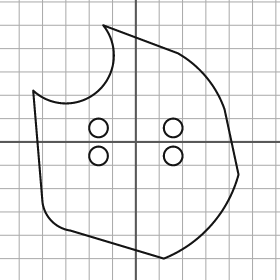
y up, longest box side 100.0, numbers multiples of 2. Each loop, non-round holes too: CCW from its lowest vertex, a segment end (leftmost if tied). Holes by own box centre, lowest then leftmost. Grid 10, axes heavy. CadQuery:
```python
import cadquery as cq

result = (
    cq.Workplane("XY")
    .moveTo(12.0, -50.0)
    .threePointArc((32.0, -36.0), (44.0, -14.0))
    .lineTo(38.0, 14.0)
    .threePointArc((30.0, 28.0), (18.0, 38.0))
    .lineTo(-14.0, 50.0)
    .threePointArc((-16.0, 22.0), (-44.0, 22.0))
    .lineTo(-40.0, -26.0)
    .threePointArc((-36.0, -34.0), (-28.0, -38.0))
    .close()
    .moveTo(-16.0, -6.0)
    .circle(4.0)
    .moveTo(16.0, -6.0)
    .circle(4.0)
    .moveTo(-16.0, 6.0)
    .circle(4.0)
    .moveTo(16.0, 6.0)
    .circle(4.0)
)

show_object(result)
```